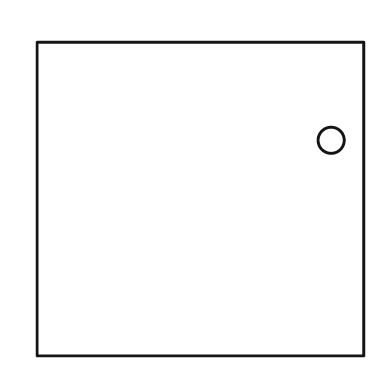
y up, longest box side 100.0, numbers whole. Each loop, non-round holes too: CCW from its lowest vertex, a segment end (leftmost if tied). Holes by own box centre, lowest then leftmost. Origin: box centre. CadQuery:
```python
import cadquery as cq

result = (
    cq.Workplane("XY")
    .moveTo(-50.0, -48.0)
    .lineTo(50.0, -48.0)
    .lineTo(50.0, 48.0)
    .lineTo(-50.0, 48.0)
    .close()
    .moveTo(40.0, 18.0)
    .circle(4.0)
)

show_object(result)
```